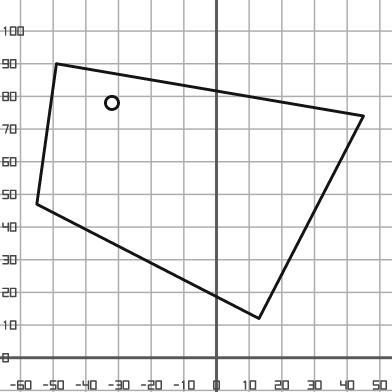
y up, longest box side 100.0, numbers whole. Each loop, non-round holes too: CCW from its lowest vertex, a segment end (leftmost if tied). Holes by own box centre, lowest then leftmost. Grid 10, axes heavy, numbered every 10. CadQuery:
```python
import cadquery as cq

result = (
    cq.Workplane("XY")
    .moveTo(13.0, 12.0)
    .lineTo(45.0, 74.0)
    .lineTo(-49.0, 90.0)
    .lineTo(-55.0, 47.0)
    .close()
    .moveTo(-32.0, 78.0)
    .circle(2.0)
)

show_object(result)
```